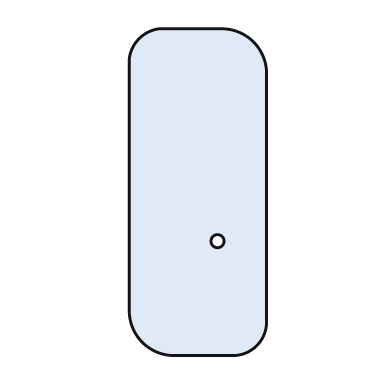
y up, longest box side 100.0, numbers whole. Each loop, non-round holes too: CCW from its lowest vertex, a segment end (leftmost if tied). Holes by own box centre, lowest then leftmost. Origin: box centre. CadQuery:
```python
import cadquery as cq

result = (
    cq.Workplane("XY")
    .moveTo(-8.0, -50.0)
    .lineTo(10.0, -50.0)
    .threePointArc((18.0, -47.0), (21.0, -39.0))
    .lineTo(21.0, 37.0)
    .threePointArc((17.0, 46.0), (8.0, 50.0))
    .lineTo(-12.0, 50.0)
    .threePointArc((-18.0, 47.0), (-21.0, 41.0))
    .lineTo(-21.0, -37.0)
    .threePointArc((-17.0, -46.0), (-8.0, -50.0))
    .close()
    .moveTo(6.0, -15.0)
    .circle(2.0)
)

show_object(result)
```